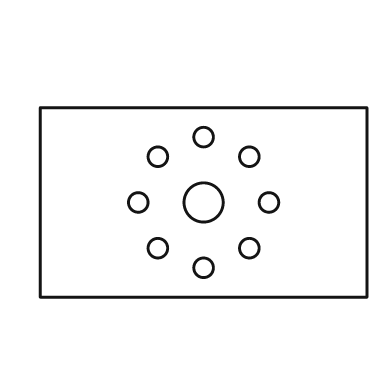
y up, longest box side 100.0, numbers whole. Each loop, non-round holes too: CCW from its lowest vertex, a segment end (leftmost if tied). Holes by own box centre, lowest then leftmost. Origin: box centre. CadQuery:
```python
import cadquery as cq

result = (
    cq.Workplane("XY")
    .moveTo(-50.0, -29.0)
    .lineTo(50.0, -29.0)
    .lineTo(50.0, 29.0)
    .lineTo(-50.0, 29.0)
    .close()
    .moveTo(0.0, -20.0)
    .circle(3.0)
    .moveTo(-14.0, -14.0)
    .circle(3.0)
    .moveTo(14.0, -14.0)
    .circle(3.0)
    .moveTo(-20.0, 0.0)
    .circle(3.0)
    .moveTo(0.0, 0.0)
    .circle(6.0)
    .moveTo(20.0, 0.0)
    .circle(3.0)
    .moveTo(-14.0, 14.0)
    .circle(3.0)
    .moveTo(14.0, 14.0)
    .circle(3.0)
    .moveTo(0.0, 20.0)
    .circle(3.0)
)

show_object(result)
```